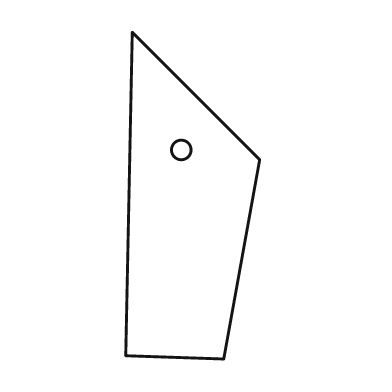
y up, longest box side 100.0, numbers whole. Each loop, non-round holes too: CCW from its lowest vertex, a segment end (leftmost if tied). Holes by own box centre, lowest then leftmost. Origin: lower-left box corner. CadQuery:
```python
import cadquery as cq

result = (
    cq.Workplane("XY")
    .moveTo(30.0, 0.0)
    .lineTo(41.0, 61.0)
    .lineTo(2.0, 100.0)
    .lineTo(0.0, 1.0)
    .close()
    .moveTo(17.0, 64.0)
    .circle(3.0)
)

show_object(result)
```